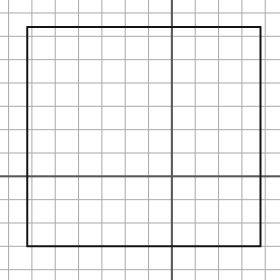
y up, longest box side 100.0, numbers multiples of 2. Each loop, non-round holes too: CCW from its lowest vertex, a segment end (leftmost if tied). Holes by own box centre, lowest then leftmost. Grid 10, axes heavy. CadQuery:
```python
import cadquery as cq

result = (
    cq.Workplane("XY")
    .moveTo(-62.0, -30.0)
    .lineTo(38.0, -30.0)
    .lineTo(38.0, 64.0)
    .lineTo(-62.0, 64.0)
    .close()
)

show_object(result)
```